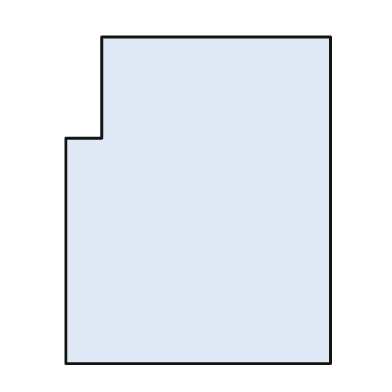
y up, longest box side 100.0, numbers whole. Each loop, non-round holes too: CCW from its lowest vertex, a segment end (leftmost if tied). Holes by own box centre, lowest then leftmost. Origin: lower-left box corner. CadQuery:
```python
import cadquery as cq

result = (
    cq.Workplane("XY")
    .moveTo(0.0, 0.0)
    .lineTo(81.0, 0.0)
    .lineTo(81.0, 100.0)
    .lineTo(11.0, 100.0)
    .lineTo(11.0, 69.0)
    .lineTo(0.0, 69.0)
    .close()
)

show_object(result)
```